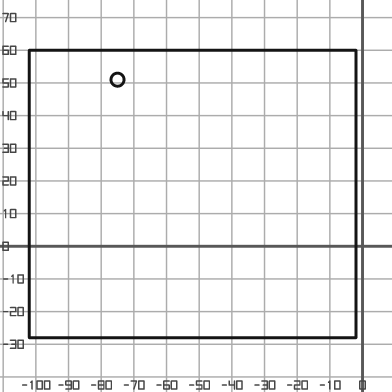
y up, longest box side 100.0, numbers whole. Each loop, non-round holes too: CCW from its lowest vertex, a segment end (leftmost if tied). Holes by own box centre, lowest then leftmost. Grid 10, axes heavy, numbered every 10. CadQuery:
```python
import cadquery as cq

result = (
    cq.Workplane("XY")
    .moveTo(-102.0, -28.0)
    .lineTo(-2.0, -28.0)
    .lineTo(-2.0, 60.0)
    .lineTo(-102.0, 60.0)
    .close()
    .moveTo(-75.0, 51.0)
    .circle(2.0)
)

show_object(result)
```